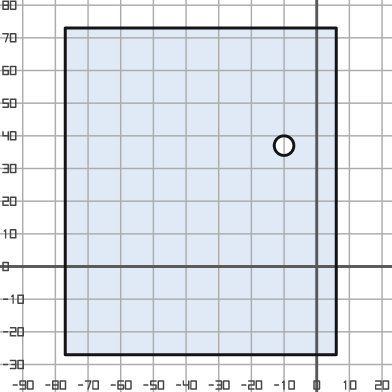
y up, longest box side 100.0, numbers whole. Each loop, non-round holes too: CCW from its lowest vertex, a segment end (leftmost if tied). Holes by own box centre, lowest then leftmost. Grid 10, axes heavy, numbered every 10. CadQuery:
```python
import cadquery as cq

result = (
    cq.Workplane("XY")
    .moveTo(-77.0, -27.0)
    .lineTo(6.0, -27.0)
    .lineTo(6.0, 73.0)
    .lineTo(-77.0, 73.0)
    .close()
    .moveTo(-10.0, 37.0)
    .circle(3.0)
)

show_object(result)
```